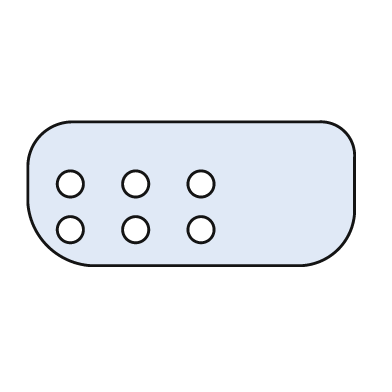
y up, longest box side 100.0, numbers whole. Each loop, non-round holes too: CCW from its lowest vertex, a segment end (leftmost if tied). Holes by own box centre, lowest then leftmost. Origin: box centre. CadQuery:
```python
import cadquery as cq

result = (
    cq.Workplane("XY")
    .moveTo(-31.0, -22.0)
    .lineTo(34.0, -22.0)
    .threePointArc((45.0, -17.0), (50.0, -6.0))
    .lineTo(50.0, 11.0)
    .threePointArc((47.0, 19.0), (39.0, 22.0))
    .lineTo(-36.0, 22.0)
    .threePointArc((-46.0, 18.0), (-50.0, 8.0))
    .lineTo(-50.0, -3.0)
    .threePointArc((-44.0, -16.0), (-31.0, -22.0))
    .close()
    .moveTo(-37.0, -11.0)
    .circle(4.0)
    .moveTo(-17.0, -11.0)
    .circle(4.0)
    .moveTo(3.0, -11.0)
    .circle(4.0)
    .moveTo(-37.0, 3.0)
    .circle(4.0)
    .moveTo(-17.0, 3.0)
    .circle(4.0)
    .moveTo(3.0, 3.0)
    .circle(4.0)
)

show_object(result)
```